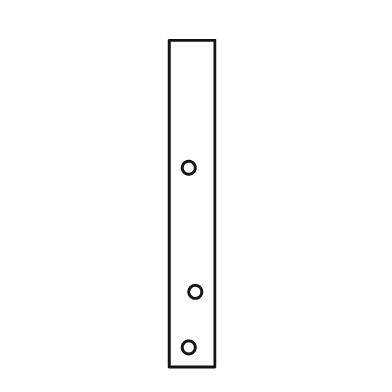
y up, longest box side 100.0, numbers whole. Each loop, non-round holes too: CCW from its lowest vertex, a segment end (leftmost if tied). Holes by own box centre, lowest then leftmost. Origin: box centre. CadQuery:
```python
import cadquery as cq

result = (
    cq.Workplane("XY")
    .moveTo(-7.0, -50.0)
    .lineTo(7.0, -50.0)
    .lineTo(7.0, 50.0)
    .lineTo(-7.0, 50.0)
    .close()
    .moveTo(-1.0, -44.0)
    .circle(2.0)
    .moveTo(1.0, -27.0)
    .circle(2.0)
    .moveTo(-1.0, 11.0)
    .circle(2.0)
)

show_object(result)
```